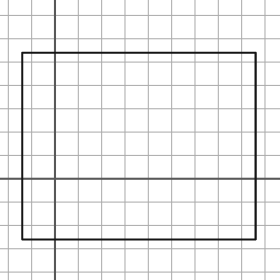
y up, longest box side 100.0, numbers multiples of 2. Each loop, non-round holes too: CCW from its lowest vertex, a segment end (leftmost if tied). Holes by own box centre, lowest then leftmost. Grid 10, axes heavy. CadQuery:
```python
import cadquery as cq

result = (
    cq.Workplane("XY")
    .moveTo(-14.0, -26.0)
    .lineTo(86.0, -26.0)
    .lineTo(86.0, 54.0)
    .lineTo(-14.0, 54.0)
    .close()
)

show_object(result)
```